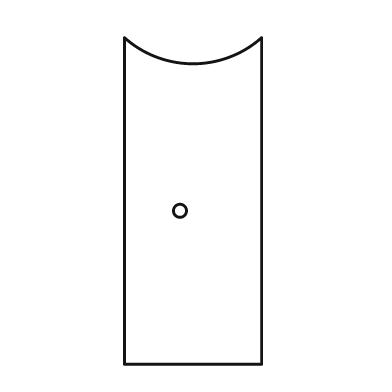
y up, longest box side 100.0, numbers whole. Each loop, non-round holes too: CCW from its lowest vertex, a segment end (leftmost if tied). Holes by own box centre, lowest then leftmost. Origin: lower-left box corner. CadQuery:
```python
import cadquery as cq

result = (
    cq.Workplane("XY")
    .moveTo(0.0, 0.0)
    .lineTo(42.0, 0.0)
    .lineTo(42.0, 100.0)
    .threePointArc((21.0, 92.0), (0.0, 100.0))
    .close()
    .moveTo(17.0, 47.0)
    .circle(2.0)
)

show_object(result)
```